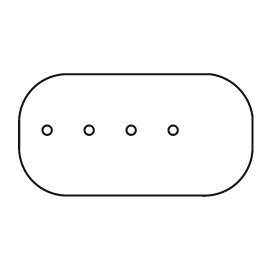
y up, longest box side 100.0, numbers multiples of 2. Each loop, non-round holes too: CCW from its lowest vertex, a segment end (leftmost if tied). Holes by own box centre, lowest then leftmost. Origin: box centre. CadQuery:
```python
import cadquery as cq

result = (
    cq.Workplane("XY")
    .moveTo(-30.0, -26.0)
    .lineTo(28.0, -26.0)
    .threePointArc((44.0, -20.0), (50.0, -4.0))
    .lineTo(50.0, 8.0)
    .threePointArc((44.0, 20.0), (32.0, 26.0))
    .lineTo(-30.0, 26.0)
    .threePointArc((-44.0, 20.0), (-50.0, 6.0))
    .lineTo(-50.0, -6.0)
    .threePointArc((-44.0, -20.0), (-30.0, -26.0))
    .close()
    .moveTo(-38.0, 2.0)
    .circle(2.0)
    .moveTo(-20.0, 2.0)
    .circle(2.0)
    .moveTo(-2.0, 2.0)
    .circle(2.0)
    .moveTo(16.0, 2.0)
    .circle(2.0)
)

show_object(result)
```